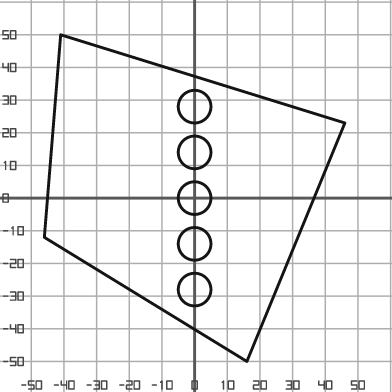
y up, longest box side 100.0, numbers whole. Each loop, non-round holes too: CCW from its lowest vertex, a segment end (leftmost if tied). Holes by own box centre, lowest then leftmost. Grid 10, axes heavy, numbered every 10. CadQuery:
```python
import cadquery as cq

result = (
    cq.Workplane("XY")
    .moveTo(16.0, -50.0)
    .lineTo(46.0, 23.0)
    .lineTo(-41.0, 50.0)
    .lineTo(-46.0, -12.0)
    .close()
    .moveTo(0.0, -28.0)
    .circle(5.0)
    .moveTo(0.0, -14.0)
    .circle(5.0)
    .moveTo(0.0, 0.0)
    .circle(5.0)
    .moveTo(0.0, 14.0)
    .circle(5.0)
    .moveTo(0.0, 28.0)
    .circle(5.0)
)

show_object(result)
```